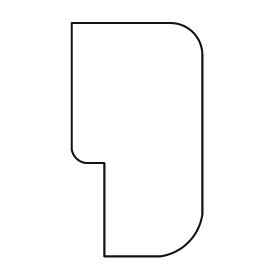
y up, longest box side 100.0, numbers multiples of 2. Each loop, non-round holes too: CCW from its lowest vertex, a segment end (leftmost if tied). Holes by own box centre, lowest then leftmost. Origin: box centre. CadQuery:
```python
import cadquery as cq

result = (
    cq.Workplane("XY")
    .moveTo(-14.0, -50.0)
    .lineTo(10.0, -50.0)
    .threePointArc((22.0, -44.0), (28.0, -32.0))
    .lineTo(28.0, 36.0)
    .threePointArc((24.0, 46.0), (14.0, 50.0))
    .lineTo(-28.0, 50.0)
    .lineTo(-28.0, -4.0)
    .threePointArc((-26.0, -8.0), (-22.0, -10.0))
    .lineTo(-14.0, -10.0)
    .close()
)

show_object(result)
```